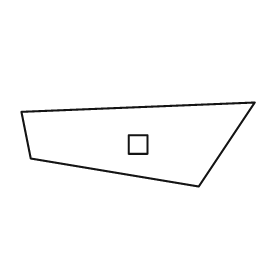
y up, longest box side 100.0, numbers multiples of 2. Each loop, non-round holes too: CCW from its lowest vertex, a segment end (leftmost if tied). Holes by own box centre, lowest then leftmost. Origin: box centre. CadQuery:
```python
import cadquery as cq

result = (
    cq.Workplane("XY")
    .moveTo(26.0, -18.0)
    .lineTo(50.0, 18.0)
    .lineTo(-50.0, 14.0)
    .lineTo(-46.0, -6.0)
    .close()
    .moveTo(-4.0, -4.0)
    .lineTo(4.0, -4.0)
    .lineTo(4.0, 4.0)
    .lineTo(-4.0, 4.0)
    .close()
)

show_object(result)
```